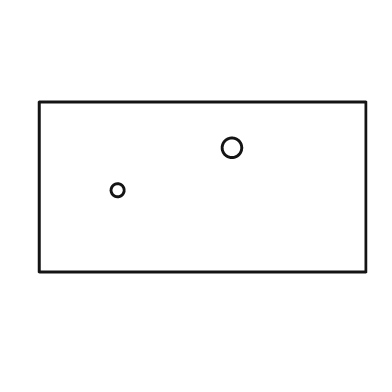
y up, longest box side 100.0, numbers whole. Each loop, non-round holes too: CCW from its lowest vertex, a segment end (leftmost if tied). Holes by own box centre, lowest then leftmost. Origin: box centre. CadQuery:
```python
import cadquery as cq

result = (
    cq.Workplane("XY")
    .moveTo(-50.0, -26.0)
    .lineTo(50.0, -26.0)
    .lineTo(50.0, 26.0)
    .lineTo(-50.0, 26.0)
    .close()
    .moveTo(-26.0, -1.0)
    .circle(2.0)
    .moveTo(9.0, 12.0)
    .circle(3.0)
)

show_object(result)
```